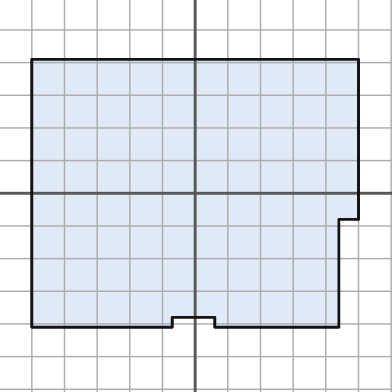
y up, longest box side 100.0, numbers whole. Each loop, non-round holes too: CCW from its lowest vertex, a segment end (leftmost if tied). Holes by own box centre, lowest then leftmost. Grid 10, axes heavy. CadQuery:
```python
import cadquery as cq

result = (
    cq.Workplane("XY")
    .moveTo(-50.0, -41.0)
    .lineTo(-7.0, -41.0)
    .lineTo(-7.0, -38.0)
    .lineTo(6.0, -38.0)
    .lineTo(6.0, -41.0)
    .lineTo(44.0, -41.0)
    .lineTo(44.0, -8.0)
    .lineTo(50.0, -8.0)
    .lineTo(50.0, 41.0)
    .lineTo(-50.0, 41.0)
    .close()
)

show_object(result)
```